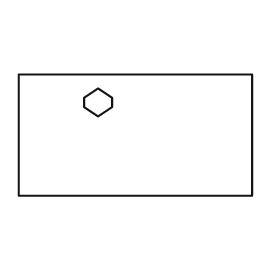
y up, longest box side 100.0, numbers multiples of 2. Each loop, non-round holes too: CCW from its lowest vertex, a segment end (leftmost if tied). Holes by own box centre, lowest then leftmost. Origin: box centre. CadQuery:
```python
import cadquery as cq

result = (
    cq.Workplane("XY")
    .moveTo(-50.0, -26.0)
    .lineTo(50.0, -26.0)
    .lineTo(50.0, 26.0)
    .lineTo(-50.0, 26.0)
    .close()
    .moveTo(-16.0, 8.0)
    .lineTo(-10.0, 12.0)
    .lineTo(-10.0, 16.0)
    .lineTo(-16.0, 20.0)
    .lineTo(-22.0, 16.0)
    .lineTo(-22.0, 12.0)
    .close()
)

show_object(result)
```